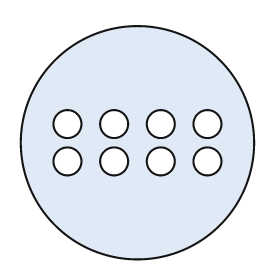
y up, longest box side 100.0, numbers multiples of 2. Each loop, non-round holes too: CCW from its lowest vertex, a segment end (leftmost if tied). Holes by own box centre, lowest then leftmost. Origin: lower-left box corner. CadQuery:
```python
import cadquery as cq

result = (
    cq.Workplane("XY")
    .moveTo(50.0, 50.0)
    .circle(50.0)
    .moveTo(20.0, 42.0)
    .circle(6.0)
    .moveTo(40.0, 42.0)
    .circle(6.0)
    .moveTo(60.0, 42.0)
    .circle(6.0)
    .moveTo(80.0, 42.0)
    .circle(6.0)
    .moveTo(20.0, 58.0)
    .circle(6.0)
    .moveTo(40.0, 58.0)
    .circle(6.0)
    .moveTo(60.0, 58.0)
    .circle(6.0)
    .moveTo(80.0, 58.0)
    .circle(6.0)
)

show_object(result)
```